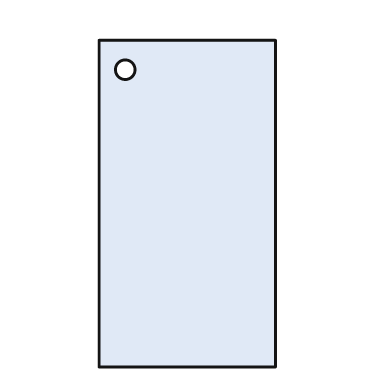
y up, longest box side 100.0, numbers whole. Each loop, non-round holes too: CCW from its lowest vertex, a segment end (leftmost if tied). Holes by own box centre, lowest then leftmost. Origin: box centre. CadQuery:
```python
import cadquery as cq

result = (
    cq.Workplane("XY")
    .moveTo(-27.0, -50.0)
    .lineTo(27.0, -50.0)
    .lineTo(27.0, 50.0)
    .lineTo(-27.0, 50.0)
    .close()
    .moveTo(-19.0, 41.0)
    .circle(3.0)
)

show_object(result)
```